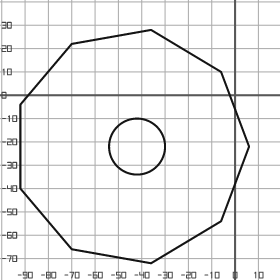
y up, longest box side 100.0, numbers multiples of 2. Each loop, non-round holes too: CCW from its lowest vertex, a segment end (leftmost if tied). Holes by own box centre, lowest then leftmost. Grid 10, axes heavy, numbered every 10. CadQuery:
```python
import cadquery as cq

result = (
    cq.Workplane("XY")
    .moveTo(-36.0, -72.0)
    .lineTo(-6.0, -54.0)
    .lineTo(6.0, -22.0)
    .lineTo(-6.0, 10.0)
    .lineTo(-36.0, 28.0)
    .lineTo(-70.0, 22.0)
    .lineTo(-92.0, -4.0)
    .lineTo(-92.0, -40.0)
    .lineTo(-70.0, -66.0)
    .close()
    .moveTo(-42.0, -22.0)
    .circle(12.0)
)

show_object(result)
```